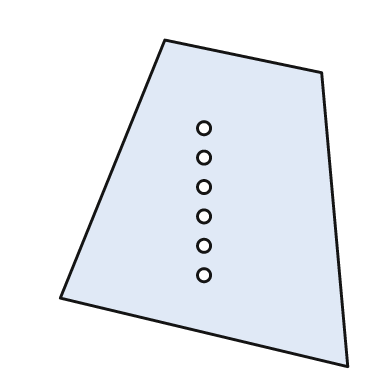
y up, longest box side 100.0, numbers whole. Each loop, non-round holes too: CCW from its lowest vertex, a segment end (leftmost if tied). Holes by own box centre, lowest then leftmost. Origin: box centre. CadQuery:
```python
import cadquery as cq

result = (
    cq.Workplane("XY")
    .moveTo(44.0, -50.0)
    .lineTo(36.0, 40.0)
    .lineTo(-12.0, 50.0)
    .lineTo(-44.0, -29.0)
    .close()
    .moveTo(0.0, -22.0)
    .circle(2.0)
    .moveTo(0.0, -13.0)
    .circle(2.0)
    .moveTo(0.0, -4.0)
    .circle(2.0)
    .moveTo(0.0, 5.0)
    .circle(2.0)
    .moveTo(0.0, 14.0)
    .circle(2.0)
    .moveTo(0.0, 23.0)
    .circle(2.0)
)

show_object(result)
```